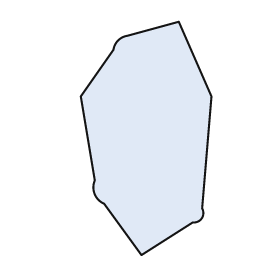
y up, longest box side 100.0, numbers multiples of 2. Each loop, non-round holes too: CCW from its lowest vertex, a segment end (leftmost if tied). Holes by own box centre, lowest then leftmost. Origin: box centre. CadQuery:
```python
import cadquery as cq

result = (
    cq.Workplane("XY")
    .moveTo(-2.0, -50.0)
    .lineTo(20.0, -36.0)
    .threePointArc((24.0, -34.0), (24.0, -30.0))
    .lineTo(28.0, 18.0)
    .lineTo(14.0, 50.0)
    .lineTo(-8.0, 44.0)
    .threePointArc((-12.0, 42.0), (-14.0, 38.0))
    .lineTo(-28.0, 18.0)
    .lineTo(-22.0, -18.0)
    .threePointArc((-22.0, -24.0), (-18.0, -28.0))
    .close()
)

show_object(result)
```